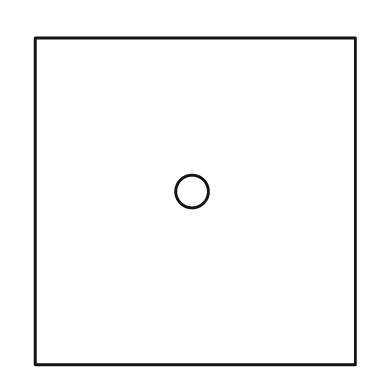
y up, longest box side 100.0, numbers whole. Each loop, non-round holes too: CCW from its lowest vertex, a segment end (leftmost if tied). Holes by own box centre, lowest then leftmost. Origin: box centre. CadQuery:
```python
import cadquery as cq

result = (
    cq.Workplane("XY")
    .moveTo(-49.0, -50.0)
    .lineTo(49.0, -50.0)
    .lineTo(49.0, 50.0)
    .lineTo(-49.0, 50.0)
    .close()
    .moveTo(-1.0, 3.0)
    .circle(5.0)
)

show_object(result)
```